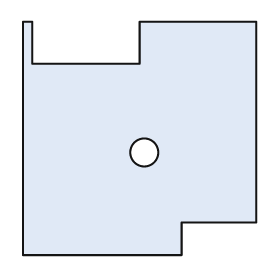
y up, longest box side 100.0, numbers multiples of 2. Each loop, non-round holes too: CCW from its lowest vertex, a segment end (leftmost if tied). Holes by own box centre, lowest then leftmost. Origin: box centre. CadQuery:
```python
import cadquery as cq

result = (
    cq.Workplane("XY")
    .moveTo(-50.0, -50.0)
    .lineTo(18.0, -50.0)
    .lineTo(18.0, -36.0)
    .lineTo(50.0, -36.0)
    .lineTo(50.0, 50.0)
    .lineTo(0.0, 50.0)
    .lineTo(0.0, 32.0)
    .lineTo(-46.0, 32.0)
    .lineTo(-46.0, 50.0)
    .lineTo(-50.0, 50.0)
    .close()
    .moveTo(2.0, -6.0)
    .circle(6.0)
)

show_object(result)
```